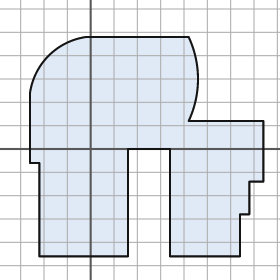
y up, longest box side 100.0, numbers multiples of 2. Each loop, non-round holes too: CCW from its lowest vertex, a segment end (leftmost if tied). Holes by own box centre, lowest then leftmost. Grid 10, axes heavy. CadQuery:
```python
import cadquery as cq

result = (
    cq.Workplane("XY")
    .moveTo(-22.0, -46.0)
    .lineTo(16.0, -46.0)
    .lineTo(16.0, 0.0)
    .lineTo(34.0, 0.0)
    .lineTo(34.0, -46.0)
    .lineTo(64.0, -46.0)
    .lineTo(64.0, -28.0)
    .lineTo(68.0, -28.0)
    .lineTo(68.0, -14.0)
    .lineTo(74.0, -14.0)
    .lineTo(74.0, 12.0)
    .lineTo(42.0, 12.0)
    .threePointArc((46.0, 30.0), (42.0, 48.0))
    .lineTo(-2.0, 48.0)
    .threePointArc((-18.0, 40.0), (-26.0, 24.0))
    .lineTo(-26.0, -6.0)
    .lineTo(-22.0, -6.0)
    .close()
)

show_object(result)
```